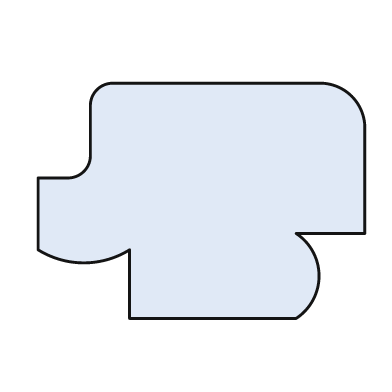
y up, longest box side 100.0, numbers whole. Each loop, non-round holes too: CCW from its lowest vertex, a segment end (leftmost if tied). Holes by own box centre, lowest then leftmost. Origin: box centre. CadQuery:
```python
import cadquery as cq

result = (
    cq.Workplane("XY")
    .moveTo(-22.0, -36.0)
    .lineTo(29.0, -36.0)
    .threePointArc((36.0, -23.0), (29.0, -10.0))
    .lineTo(50.0, -10.0)
    .lineTo(50.0, 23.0)
    .threePointArc((46.0, 32.0), (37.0, 36.0))
    .lineTo(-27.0, 36.0)
    .threePointArc((-32.0, 34.0), (-34.0, 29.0))
    .lineTo(-34.0, 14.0)
    .threePointArc((-36.0, 9.0), (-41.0, 7.0))
    .lineTo(-50.0, 7.0)
    .lineTo(-50.0, -15.0)
    .threePointArc((-36.0, -19.0), (-22.0, -15.0))
    .close()
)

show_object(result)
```